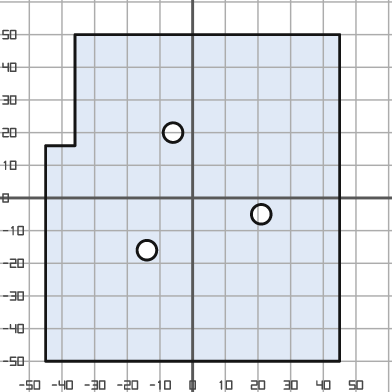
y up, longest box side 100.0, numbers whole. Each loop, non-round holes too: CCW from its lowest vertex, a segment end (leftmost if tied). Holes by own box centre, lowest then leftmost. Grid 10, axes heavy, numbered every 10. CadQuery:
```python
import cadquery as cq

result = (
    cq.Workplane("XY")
    .moveTo(-45.0, -50.0)
    .lineTo(45.0, -50.0)
    .lineTo(45.0, 50.0)
    .lineTo(-36.0, 50.0)
    .lineTo(-36.0, 16.0)
    .lineTo(-45.0, 16.0)
    .close()
    .moveTo(-14.0, -16.0)
    .circle(3.0)
    .moveTo(21.0, -5.0)
    .circle(3.0)
    .moveTo(-6.0, 20.0)
    .circle(3.0)
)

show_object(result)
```